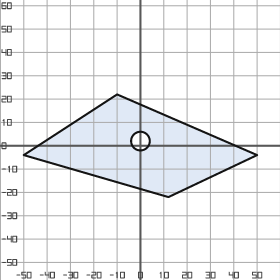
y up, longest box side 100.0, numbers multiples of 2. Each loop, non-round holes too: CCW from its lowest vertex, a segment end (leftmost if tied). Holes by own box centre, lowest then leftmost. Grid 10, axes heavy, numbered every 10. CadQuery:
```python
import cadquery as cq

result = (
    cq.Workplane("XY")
    .moveTo(12.0, -22.0)
    .lineTo(50.0, -4.0)
    .lineTo(-10.0, 22.0)
    .lineTo(-50.0, -4.0)
    .close()
    .moveTo(0.0, 2.0)
    .circle(4.0)
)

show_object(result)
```